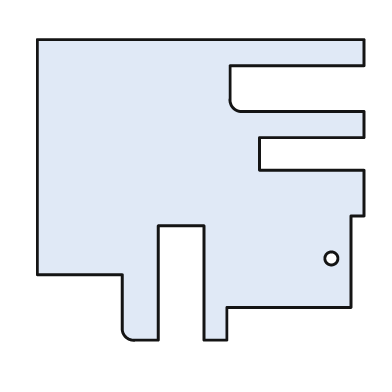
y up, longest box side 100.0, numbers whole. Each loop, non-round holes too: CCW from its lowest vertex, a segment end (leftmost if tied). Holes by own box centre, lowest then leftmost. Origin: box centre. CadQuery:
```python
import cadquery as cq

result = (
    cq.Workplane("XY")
    .moveTo(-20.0, -46.0)
    .lineTo(-13.0, -46.0)
    .lineTo(-13.0, -11.0)
    .lineTo(1.0, -11.0)
    .lineTo(1.0, -46.0)
    .lineTo(8.0, -46.0)
    .lineTo(8.0, -36.0)
    .lineTo(46.0, -36.0)
    .lineTo(46.0, -8.0)
    .lineTo(50.0, -8.0)
    .lineTo(50.0, 6.0)
    .lineTo(18.0, 6.0)
    .lineTo(18.0, 16.0)
    .lineTo(50.0, 16.0)
    .lineTo(50.0, 24.0)
    .lineTo(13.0, 24.0)
    .threePointArc((10.0, 25.0), (9.0, 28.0))
    .lineTo(9.0, 38.0)
    .lineTo(50.0, 38.0)
    .lineTo(50.0, 46.0)
    .lineTo(-50.0, 46.0)
    .lineTo(-50.0, -26.0)
    .lineTo(-24.0, -26.0)
    .lineTo(-24.0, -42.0)
    .threePointArc((-23.0, -45.0), (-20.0, -46.0))
    .close()
    .moveTo(40.0, -21.0)
    .circle(2.0)
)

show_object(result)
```